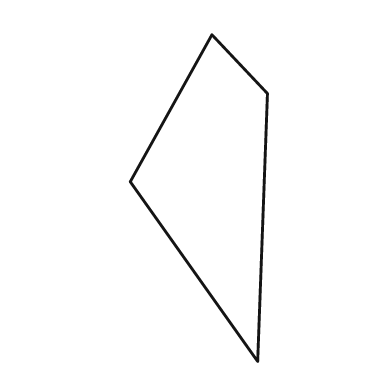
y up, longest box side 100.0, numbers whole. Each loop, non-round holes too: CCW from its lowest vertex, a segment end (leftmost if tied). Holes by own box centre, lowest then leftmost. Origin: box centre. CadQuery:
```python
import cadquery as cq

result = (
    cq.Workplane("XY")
    .moveTo(18.0, -50.0)
    .lineTo(21.0, 32.0)
    .lineTo(4.0, 50.0)
    .lineTo(-21.0, 5.0)
    .close()
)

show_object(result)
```